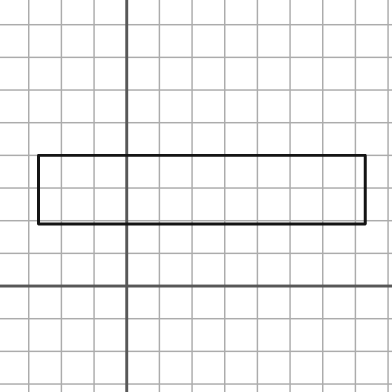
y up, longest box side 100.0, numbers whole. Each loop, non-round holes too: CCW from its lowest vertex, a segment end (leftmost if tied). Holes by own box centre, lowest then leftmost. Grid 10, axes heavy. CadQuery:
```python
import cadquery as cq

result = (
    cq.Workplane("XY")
    .moveTo(-27.0, 19.0)
    .lineTo(73.0, 19.0)
    .lineTo(73.0, 40.0)
    .lineTo(-27.0, 40.0)
    .close()
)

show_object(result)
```